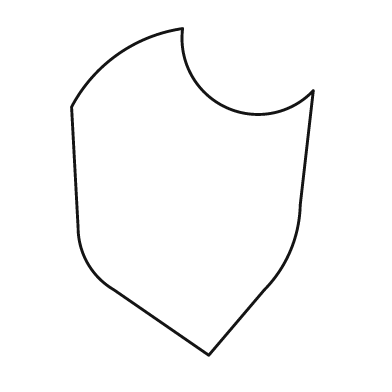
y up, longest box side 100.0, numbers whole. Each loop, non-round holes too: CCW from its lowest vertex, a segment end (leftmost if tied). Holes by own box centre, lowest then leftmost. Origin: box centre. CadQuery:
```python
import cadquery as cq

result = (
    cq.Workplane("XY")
    .moveTo(5.0, -50.0)
    .lineTo(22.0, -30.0)
    .threePointArc((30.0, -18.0), (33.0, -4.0))
    .lineTo(37.0, 31.0)
    .threePointArc((10.0, 26.0), (-3.0, 50.0))
    .threePointArc((-23.0, 42.0), (-37.0, 26.0))
    .lineTo(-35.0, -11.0)
    .threePointArc((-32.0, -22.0), (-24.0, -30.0))
    .close()
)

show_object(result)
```